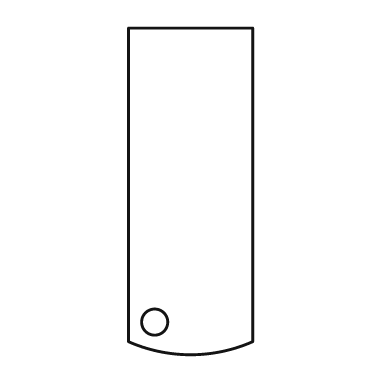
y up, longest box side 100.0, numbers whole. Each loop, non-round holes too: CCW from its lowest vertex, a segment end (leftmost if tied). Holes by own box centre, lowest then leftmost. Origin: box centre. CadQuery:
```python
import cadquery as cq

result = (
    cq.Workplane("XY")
    .moveTo(-19.0, -46.0)
    .threePointArc((0.0, -50.0), (19.0, -46.0))
    .lineTo(19.0, 50.0)
    .lineTo(-19.0, 50.0)
    .close()
    .moveTo(-11.0, -40.0)
    .circle(4.0)
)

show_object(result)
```